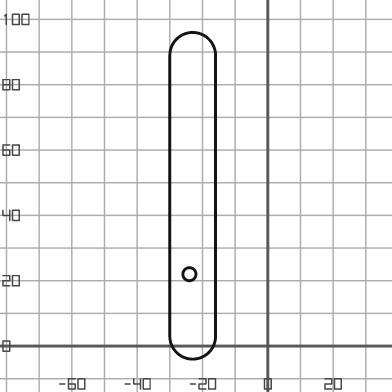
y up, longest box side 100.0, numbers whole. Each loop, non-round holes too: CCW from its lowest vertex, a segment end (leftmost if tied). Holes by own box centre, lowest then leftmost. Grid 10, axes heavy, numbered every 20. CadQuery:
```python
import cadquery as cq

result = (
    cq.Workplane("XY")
    .moveTo(-30.0, 3.0)
    .threePointArc((-23.0, -4.0), (-16.0, 3.0))
    .lineTo(-16.0, 89.0)
    .threePointArc((-23.0, 96.0), (-30.0, 89.0))
    .close()
    .moveTo(-24.0, 22.0)
    .circle(2.0)
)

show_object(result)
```